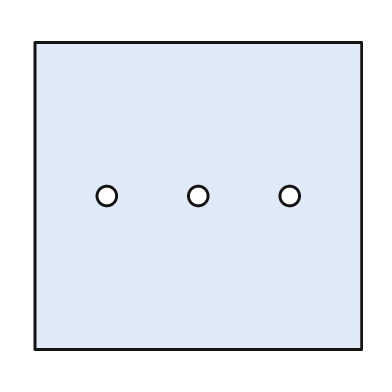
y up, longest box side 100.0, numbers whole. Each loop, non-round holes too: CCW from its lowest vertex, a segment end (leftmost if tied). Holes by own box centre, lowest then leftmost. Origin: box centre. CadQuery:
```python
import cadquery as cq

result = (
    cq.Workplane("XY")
    .moveTo(-50.0, -47.0)
    .lineTo(50.0, -47.0)
    .lineTo(50.0, 47.0)
    .lineTo(-50.0, 47.0)
    .close()
    .moveTo(-28.0, 0.0)
    .circle(3.0)
    .moveTo(0.0, 0.0)
    .circle(3.0)
    .moveTo(28.0, 0.0)
    .circle(3.0)
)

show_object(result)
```